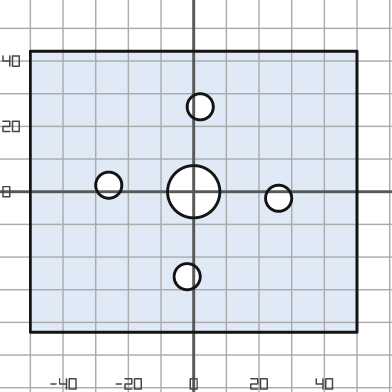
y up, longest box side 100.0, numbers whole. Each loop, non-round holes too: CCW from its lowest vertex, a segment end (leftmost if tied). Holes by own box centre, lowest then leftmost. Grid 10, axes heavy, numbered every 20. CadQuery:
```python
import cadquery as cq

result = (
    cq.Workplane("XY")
    .moveTo(-50.0, -43.0)
    .lineTo(50.0, -43.0)
    .lineTo(50.0, 43.0)
    .lineTo(-50.0, 43.0)
    .close()
    .moveTo(-2.0, -26.0)
    .circle(4.0)
    .moveTo(26.0, -2.0)
    .circle(4.0)
    .moveTo(0.0, 0.0)
    .circle(8.0)
    .moveTo(-26.0, 2.0)
    .circle(4.0)
    .moveTo(2.0, 26.0)
    .circle(4.0)
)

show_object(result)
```